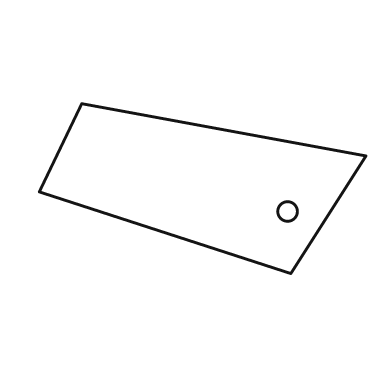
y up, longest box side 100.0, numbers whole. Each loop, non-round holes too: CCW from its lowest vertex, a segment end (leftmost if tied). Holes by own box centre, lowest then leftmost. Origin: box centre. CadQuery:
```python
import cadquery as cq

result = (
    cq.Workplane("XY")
    .moveTo(27.0, -26.0)
    .lineTo(50.0, 10.0)
    .lineTo(-37.0, 26.0)
    .lineTo(-50.0, -1.0)
    .close()
    .moveTo(26.0, -7.0)
    .circle(3.0)
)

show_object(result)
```